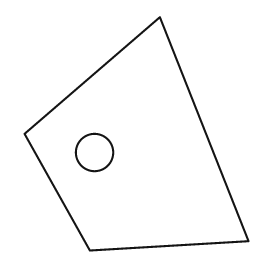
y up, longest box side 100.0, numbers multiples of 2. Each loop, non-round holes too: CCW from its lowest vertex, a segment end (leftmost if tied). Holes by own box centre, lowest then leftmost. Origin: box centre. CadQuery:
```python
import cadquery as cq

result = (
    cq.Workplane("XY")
    .moveTo(-20.0, -50.0)
    .lineTo(48.0, -46.0)
    .lineTo(10.0, 50.0)
    .lineTo(-48.0, 0.0)
    .close()
    .moveTo(-18.0, -8.0)
    .circle(8.0)
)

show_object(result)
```